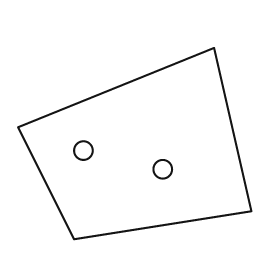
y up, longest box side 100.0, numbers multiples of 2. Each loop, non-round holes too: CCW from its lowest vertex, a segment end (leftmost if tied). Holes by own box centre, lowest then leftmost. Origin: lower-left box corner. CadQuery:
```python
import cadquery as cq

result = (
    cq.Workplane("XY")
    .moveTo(24.0, 0.0)
    .lineTo(100.0, 12.0)
    .lineTo(84.0, 82.0)
    .lineTo(0.0, 48.0)
    .close()
    .moveTo(62.0, 30.0)
    .circle(4.0)
    .moveTo(28.0, 38.0)
    .circle(4.0)
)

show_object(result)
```